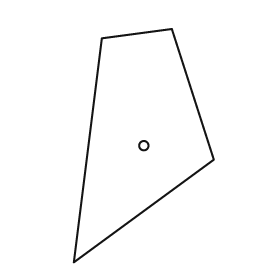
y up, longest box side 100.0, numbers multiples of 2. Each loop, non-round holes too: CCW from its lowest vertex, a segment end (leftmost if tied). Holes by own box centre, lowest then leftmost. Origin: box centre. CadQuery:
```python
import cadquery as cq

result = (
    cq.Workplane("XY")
    .moveTo(-30.0, -50.0)
    .lineTo(30.0, -6.0)
    .lineTo(12.0, 50.0)
    .lineTo(-18.0, 46.0)
    .close()
    .moveTo(0.0, 0.0)
    .circle(2.0)
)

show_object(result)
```